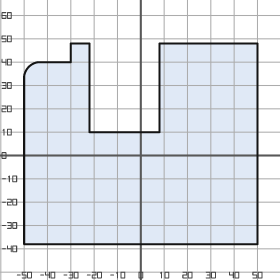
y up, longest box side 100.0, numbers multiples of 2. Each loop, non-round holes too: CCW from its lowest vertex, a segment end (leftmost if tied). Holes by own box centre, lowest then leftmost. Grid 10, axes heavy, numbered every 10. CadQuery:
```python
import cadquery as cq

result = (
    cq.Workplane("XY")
    .moveTo(-50.0, -38.0)
    .lineTo(50.0, -38.0)
    .lineTo(50.0, 48.0)
    .lineTo(8.0, 48.0)
    .lineTo(8.0, 10.0)
    .lineTo(-22.0, 10.0)
    .lineTo(-22.0, 48.0)
    .lineTo(-30.0, 48.0)
    .lineTo(-30.0, 40.0)
    .lineTo(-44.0, 40.0)
    .threePointArc((-48.0, 38.0), (-50.0, 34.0))
    .close()
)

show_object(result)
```